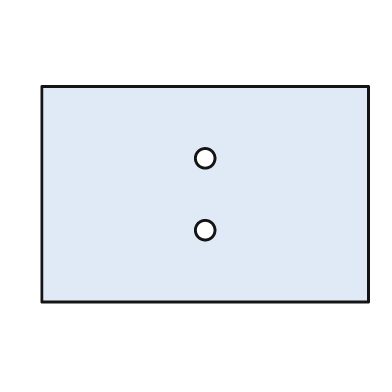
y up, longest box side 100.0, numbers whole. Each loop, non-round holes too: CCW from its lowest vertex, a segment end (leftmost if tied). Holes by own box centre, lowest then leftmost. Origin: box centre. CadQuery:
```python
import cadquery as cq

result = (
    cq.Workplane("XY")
    .moveTo(-50.0, -33.0)
    .lineTo(50.0, -33.0)
    .lineTo(50.0, 33.0)
    .lineTo(-50.0, 33.0)
    .close()
    .moveTo(0.0, -11.0)
    .circle(3.0)
    .moveTo(0.0, 11.0)
    .circle(3.0)
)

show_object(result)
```